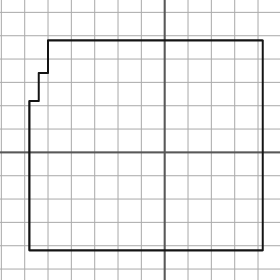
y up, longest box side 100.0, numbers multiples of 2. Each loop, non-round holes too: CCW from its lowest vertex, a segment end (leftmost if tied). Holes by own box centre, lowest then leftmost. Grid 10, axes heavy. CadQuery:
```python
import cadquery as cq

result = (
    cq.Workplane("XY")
    .moveTo(-58.0, -42.0)
    .lineTo(42.0, -42.0)
    .lineTo(42.0, 48.0)
    .lineTo(-50.0, 48.0)
    .lineTo(-50.0, 34.0)
    .lineTo(-54.0, 34.0)
    .lineTo(-54.0, 22.0)
    .lineTo(-58.0, 22.0)
    .close()
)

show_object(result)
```